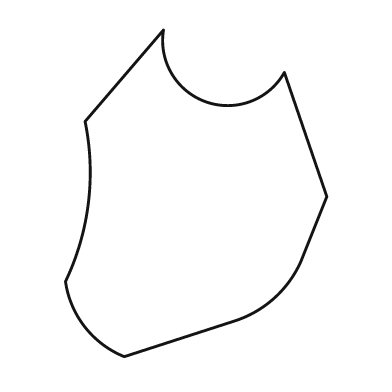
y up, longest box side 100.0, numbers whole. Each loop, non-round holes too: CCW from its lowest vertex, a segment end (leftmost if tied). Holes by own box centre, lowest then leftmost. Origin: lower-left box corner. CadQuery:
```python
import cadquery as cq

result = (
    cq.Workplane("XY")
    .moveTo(18.0, 0.0)
    .lineTo(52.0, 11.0)
    .threePointArc((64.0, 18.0), (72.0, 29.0))
    .lineTo(80.0, 49.0)
    .lineTo(67.0, 87.0)
    .threePointArc((43.0, 78.0), (30.0, 100.0))
    .lineTo(6.0, 72.0)
    .threePointArc((7.0, 47.0), (0.0, 23.0))
    .threePointArc((6.0, 9.0), (18.0, 0.0))
    .close()
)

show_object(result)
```